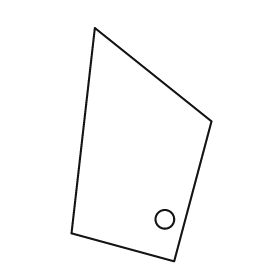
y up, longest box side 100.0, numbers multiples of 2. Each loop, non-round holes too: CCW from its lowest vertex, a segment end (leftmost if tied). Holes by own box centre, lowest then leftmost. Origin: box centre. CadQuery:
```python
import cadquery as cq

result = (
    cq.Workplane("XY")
    .moveTo(14.0, -50.0)
    .lineTo(30.0, 10.0)
    .lineTo(-20.0, 50.0)
    .lineTo(-30.0, -38.0)
    .close()
    .moveTo(10.0, -32.0)
    .circle(4.0)
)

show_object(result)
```